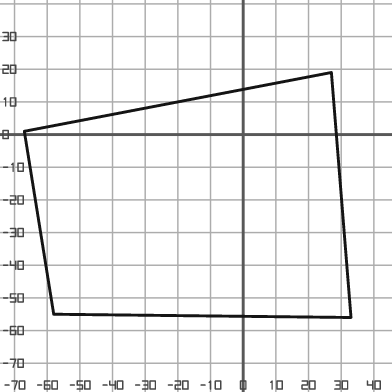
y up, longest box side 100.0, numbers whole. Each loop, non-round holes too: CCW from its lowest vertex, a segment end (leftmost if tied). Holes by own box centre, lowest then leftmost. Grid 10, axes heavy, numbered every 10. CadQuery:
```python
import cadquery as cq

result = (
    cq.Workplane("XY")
    .moveTo(33.0, -56.0)
    .lineTo(27.0, 19.0)
    .lineTo(-67.0, 1.0)
    .lineTo(-58.0, -55.0)
    .close()
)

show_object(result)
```